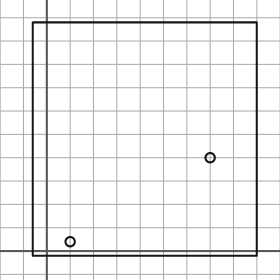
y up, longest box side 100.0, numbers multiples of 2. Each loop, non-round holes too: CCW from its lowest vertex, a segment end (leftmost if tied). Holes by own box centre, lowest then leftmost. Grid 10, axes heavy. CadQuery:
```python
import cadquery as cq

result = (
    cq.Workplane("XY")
    .moveTo(-6.0, -2.0)
    .lineTo(90.0, -2.0)
    .lineTo(90.0, 98.0)
    .lineTo(-6.0, 98.0)
    .close()
    .moveTo(10.0, 4.0)
    .circle(2.0)
    .moveTo(70.0, 40.0)
    .circle(2.0)
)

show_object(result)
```